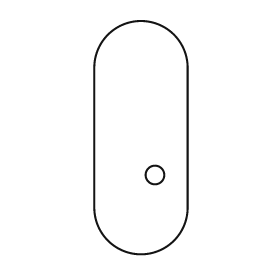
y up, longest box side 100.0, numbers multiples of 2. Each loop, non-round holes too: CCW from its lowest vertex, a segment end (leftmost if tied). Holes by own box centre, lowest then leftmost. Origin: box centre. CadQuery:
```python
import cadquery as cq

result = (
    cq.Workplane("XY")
    .moveTo(-20.0, -30.0)
    .threePointArc((0.0, -50.0), (20.0, -30.0))
    .lineTo(20.0, 30.0)
    .threePointArc((0.0, 50.0), (-20.0, 30.0))
    .close()
    .moveTo(6.0, -16.0)
    .circle(4.0)
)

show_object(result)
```